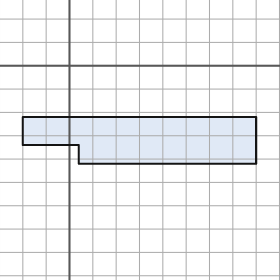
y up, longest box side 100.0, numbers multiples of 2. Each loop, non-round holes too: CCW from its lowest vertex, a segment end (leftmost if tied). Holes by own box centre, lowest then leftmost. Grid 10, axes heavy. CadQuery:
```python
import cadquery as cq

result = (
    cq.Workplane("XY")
    .moveTo(4.0, -42.0)
    .lineTo(80.0, -42.0)
    .lineTo(80.0, -22.0)
    .lineTo(-20.0, -22.0)
    .lineTo(-20.0, -34.0)
    .lineTo(4.0, -34.0)
    .close()
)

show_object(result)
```